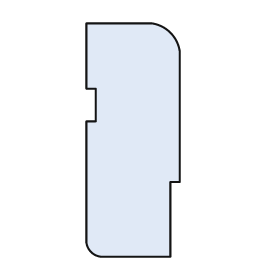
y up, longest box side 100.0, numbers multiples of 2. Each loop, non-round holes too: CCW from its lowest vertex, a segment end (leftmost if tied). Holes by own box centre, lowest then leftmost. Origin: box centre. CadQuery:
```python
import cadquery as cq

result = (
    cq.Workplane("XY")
    .moveTo(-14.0, -50.0)
    .lineTo(16.0, -50.0)
    .lineTo(16.0, -18.0)
    .lineTo(20.0, -18.0)
    .lineTo(20.0, 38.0)
    .threePointArc((16.0, 46.0), (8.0, 50.0))
    .lineTo(-20.0, 50.0)
    .lineTo(-20.0, 22.0)
    .lineTo(-16.0, 22.0)
    .lineTo(-16.0, 8.0)
    .lineTo(-20.0, 8.0)
    .lineTo(-20.0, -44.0)
    .threePointArc((-18.0, -48.0), (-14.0, -50.0))
    .close()
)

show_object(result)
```